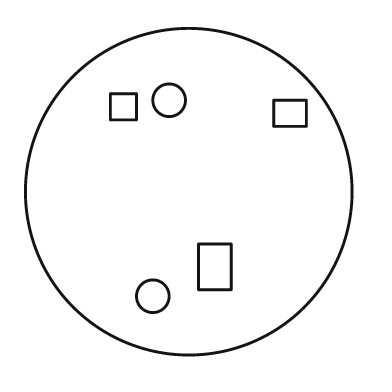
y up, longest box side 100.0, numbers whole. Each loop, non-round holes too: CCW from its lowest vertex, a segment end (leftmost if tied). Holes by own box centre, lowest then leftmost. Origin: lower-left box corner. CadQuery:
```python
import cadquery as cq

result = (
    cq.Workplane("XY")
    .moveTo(50.0, 50.0)
    .circle(50.0)
    .moveTo(39.0, 18.0)
    .circle(5.0)
    .moveTo(53.0, 20.0)
    .lineTo(63.0, 20.0)
    .lineTo(63.0, 34.0)
    .lineTo(53.0, 34.0)
    .close()
    .moveTo(76.0, 70.0)
    .lineTo(86.0, 70.0)
    .lineTo(86.0, 78.0)
    .lineTo(76.0, 78.0)
    .close()
    .moveTo(26.0, 72.0)
    .lineTo(34.0, 72.0)
    .lineTo(34.0, 80.0)
    .lineTo(26.0, 80.0)
    .close()
    .moveTo(44.0, 78.0)
    .circle(5.0)
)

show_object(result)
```